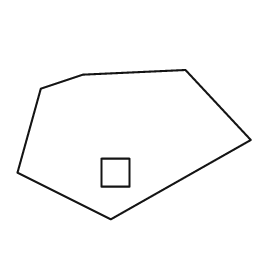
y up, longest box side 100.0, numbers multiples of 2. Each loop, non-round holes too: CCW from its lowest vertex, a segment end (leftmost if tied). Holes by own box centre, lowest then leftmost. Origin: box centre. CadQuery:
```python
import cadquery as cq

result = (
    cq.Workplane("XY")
    .moveTo(-10.0, -32.0)
    .lineTo(50.0, 2.0)
    .lineTo(22.0, 32.0)
    .lineTo(-22.0, 30.0)
    .lineTo(-40.0, 24.0)
    .lineTo(-50.0, -12.0)
    .close()
    .moveTo(-14.0, -18.0)
    .lineTo(-2.0, -18.0)
    .lineTo(-2.0, -6.0)
    .lineTo(-14.0, -6.0)
    .close()
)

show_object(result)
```